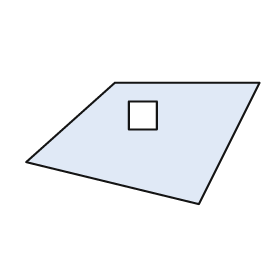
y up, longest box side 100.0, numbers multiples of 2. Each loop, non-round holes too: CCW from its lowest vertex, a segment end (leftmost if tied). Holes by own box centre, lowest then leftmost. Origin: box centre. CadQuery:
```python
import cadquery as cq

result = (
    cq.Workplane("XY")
    .moveTo(24.0, -26.0)
    .lineTo(50.0, 26.0)
    .lineTo(-12.0, 26.0)
    .lineTo(-50.0, -8.0)
    .close()
    .moveTo(-6.0, 6.0)
    .lineTo(6.0, 6.0)
    .lineTo(6.0, 18.0)
    .lineTo(-6.0, 18.0)
    .close()
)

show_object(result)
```